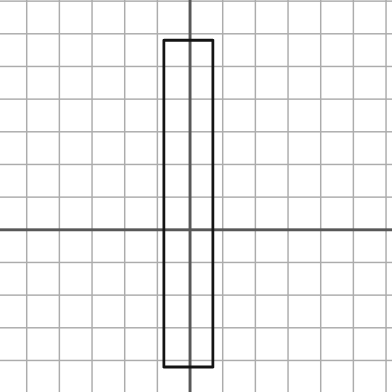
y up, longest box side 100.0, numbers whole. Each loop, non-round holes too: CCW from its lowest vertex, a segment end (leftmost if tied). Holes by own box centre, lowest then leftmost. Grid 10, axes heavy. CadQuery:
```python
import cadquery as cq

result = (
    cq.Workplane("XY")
    .moveTo(-8.0, -42.0)
    .lineTo(7.0, -42.0)
    .lineTo(7.0, 58.0)
    .lineTo(-8.0, 58.0)
    .close()
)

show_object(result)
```